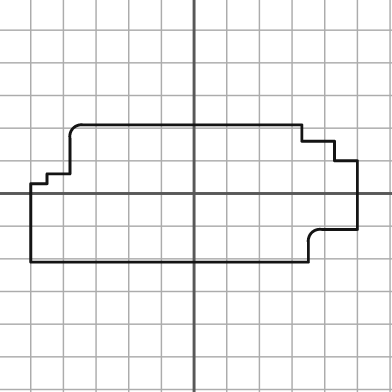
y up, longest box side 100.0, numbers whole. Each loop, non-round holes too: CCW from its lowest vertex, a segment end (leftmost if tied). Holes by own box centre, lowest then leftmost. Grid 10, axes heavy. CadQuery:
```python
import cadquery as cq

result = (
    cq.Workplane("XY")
    .moveTo(-50.0, -21.0)
    .lineTo(35.0, -21.0)
    .lineTo(35.0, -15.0)
    .threePointArc((36.0, -12.0), (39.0, -11.0))
    .lineTo(50.0, -11.0)
    .lineTo(50.0, 10.0)
    .lineTo(43.0, 10.0)
    .lineTo(43.0, 16.0)
    .lineTo(33.0, 16.0)
    .lineTo(33.0, 21.0)
    .lineTo(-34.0, 21.0)
    .threePointArc((-37.0, 20.0), (-38.0, 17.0))
    .lineTo(-38.0, 6.0)
    .lineTo(-45.0, 6.0)
    .lineTo(-45.0, 3.0)
    .lineTo(-50.0, 3.0)
    .close()
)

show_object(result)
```